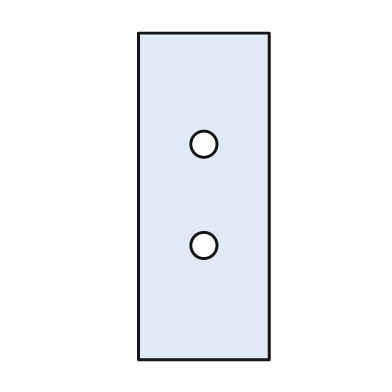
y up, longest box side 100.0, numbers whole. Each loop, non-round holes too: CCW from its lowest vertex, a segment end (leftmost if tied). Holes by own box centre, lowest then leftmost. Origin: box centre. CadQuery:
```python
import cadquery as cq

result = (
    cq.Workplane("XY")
    .moveTo(-20.0, -50.0)
    .lineTo(20.0, -50.0)
    .lineTo(20.0, 50.0)
    .lineTo(-20.0, 50.0)
    .close()
    .moveTo(0.0, -15.0)
    .circle(4.0)
    .moveTo(0.0, 16.0)
    .circle(4.0)
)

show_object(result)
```